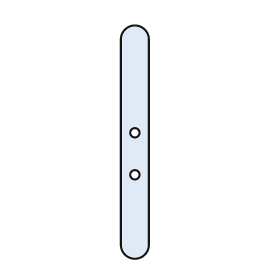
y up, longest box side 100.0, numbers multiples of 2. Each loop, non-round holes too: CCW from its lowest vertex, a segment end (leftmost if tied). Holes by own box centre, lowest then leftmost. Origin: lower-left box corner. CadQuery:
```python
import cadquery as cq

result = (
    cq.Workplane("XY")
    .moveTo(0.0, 6.0)
    .threePointArc((6.0, 0.0), (12.0, 6.0))
    .lineTo(12.0, 94.0)
    .threePointArc((6.0, 100.0), (0.0, 94.0))
    .close()
    .moveTo(6.0, 36.0)
    .circle(2.0)
    .moveTo(6.0, 54.0)
    .circle(2.0)
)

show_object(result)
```